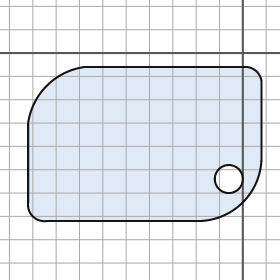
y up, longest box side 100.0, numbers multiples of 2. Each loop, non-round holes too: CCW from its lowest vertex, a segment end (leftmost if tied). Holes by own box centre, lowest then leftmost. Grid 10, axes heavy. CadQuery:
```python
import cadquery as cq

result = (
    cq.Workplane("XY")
    .moveTo(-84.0, -72.0)
    .lineTo(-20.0, -72.0)
    .threePointArc((0.0, -64.0), (8.0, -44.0))
    .lineTo(8.0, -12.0)
    .threePointArc((6.0, -8.0), (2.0, -6.0))
    .lineTo(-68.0, -6.0)
    .threePointArc((-84.0, -14.0), (-92.0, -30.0))
    .lineTo(-92.0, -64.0)
    .threePointArc((-90.0, -70.0), (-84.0, -72.0))
    .close()
    .moveTo(-6.0, -54.0)
    .circle(6.0)
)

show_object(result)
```